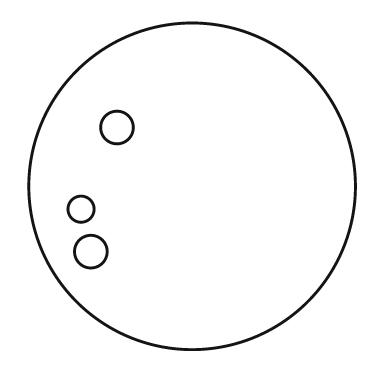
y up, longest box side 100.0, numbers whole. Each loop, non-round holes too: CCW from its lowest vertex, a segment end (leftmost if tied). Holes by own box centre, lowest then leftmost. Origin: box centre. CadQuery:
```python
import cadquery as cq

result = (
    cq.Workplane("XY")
    .moveTo(0.0, 0.0)
    .circle(50.0)
    .moveTo(-31.0, -20.0)
    .circle(5.0)
    .moveTo(-34.0, -7.0)
    .circle(4.0)
    .moveTo(-23.0, 18.0)
    .circle(5.0)
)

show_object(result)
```